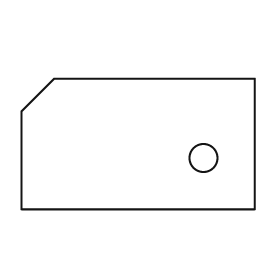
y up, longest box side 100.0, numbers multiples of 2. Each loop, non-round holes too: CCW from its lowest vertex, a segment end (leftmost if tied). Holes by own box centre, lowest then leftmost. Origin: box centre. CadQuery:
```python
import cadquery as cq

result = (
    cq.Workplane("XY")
    .moveTo(-50.0, -28.0)
    .lineTo(50.0, -28.0)
    .lineTo(50.0, 28.0)
    .lineTo(-36.0, 28.0)
    .lineTo(-50.0, 14.0)
    .close()
    .moveTo(28.0, -6.0)
    .circle(6.0)
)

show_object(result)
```